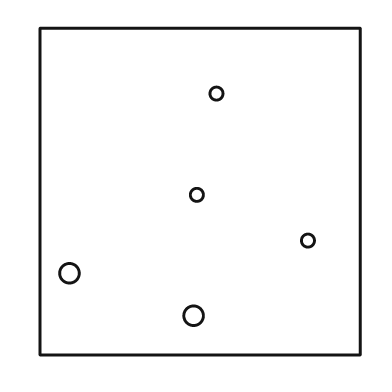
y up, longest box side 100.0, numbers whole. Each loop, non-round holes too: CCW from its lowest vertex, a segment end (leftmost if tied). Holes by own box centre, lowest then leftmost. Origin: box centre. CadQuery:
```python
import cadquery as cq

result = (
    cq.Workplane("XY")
    .moveTo(-49.0, -50.0)
    .lineTo(49.0, -50.0)
    .lineTo(49.0, 50.0)
    .lineTo(-49.0, 50.0)
    .close()
    .moveTo(-2.0, -38.0)
    .circle(3.0)
    .moveTo(-40.0, -25.0)
    .circle(3.0)
    .moveTo(33.0, -15.0)
    .circle(2.0)
    .moveTo(-1.0, -1.0)
    .circle(2.0)
    .moveTo(5.0, 30.0)
    .circle(2.0)
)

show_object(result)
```